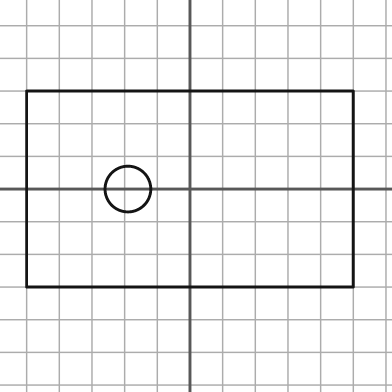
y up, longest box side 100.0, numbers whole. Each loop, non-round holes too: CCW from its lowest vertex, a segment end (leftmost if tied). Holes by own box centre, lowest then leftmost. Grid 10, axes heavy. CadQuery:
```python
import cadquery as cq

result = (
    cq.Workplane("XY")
    .moveTo(-50.0, -30.0)
    .lineTo(50.0, -30.0)
    .lineTo(50.0, 30.0)
    .lineTo(-50.0, 30.0)
    .close()
    .moveTo(-19.0, 0.0)
    .circle(7.0)
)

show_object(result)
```